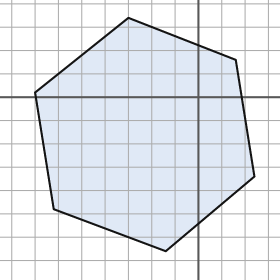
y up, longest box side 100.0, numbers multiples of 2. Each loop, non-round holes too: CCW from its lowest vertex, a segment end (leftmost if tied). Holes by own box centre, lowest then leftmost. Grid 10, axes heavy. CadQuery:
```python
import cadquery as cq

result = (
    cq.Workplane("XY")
    .moveTo(-14.0, -66.0)
    .lineTo(24.0, -34.0)
    .lineTo(16.0, 16.0)
    .lineTo(-30.0, 34.0)
    .lineTo(-70.0, 2.0)
    .lineTo(-62.0, -48.0)
    .close()
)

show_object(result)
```